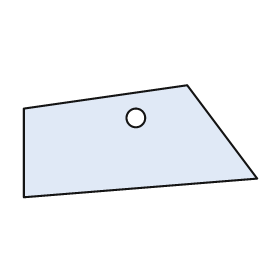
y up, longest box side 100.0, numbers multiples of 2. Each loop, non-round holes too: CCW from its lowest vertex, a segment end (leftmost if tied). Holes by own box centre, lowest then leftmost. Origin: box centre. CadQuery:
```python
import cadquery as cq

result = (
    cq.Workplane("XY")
    .moveTo(-50.0, -24.0)
    .lineTo(50.0, -16.0)
    .lineTo(20.0, 24.0)
    .lineTo(-50.0, 14.0)
    .close()
    .moveTo(-2.0, 10.0)
    .circle(4.0)
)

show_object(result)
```